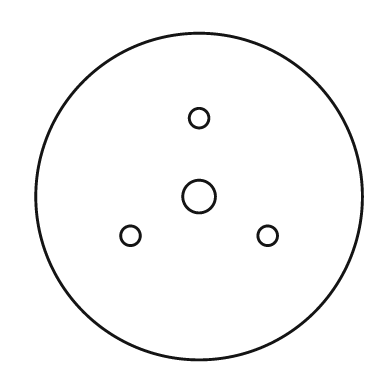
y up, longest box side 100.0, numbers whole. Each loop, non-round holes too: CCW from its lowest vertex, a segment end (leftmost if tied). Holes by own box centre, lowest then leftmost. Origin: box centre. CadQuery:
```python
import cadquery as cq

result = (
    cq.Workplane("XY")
    .moveTo(0.0, 0.0)
    .circle(50.0)
    .moveTo(-21.0, -12.0)
    .circle(3.0)
    .moveTo(21.0, -12.0)
    .circle(3.0)
    .moveTo(0.0, 0.0)
    .circle(5.0)
    .moveTo(0.0, 24.0)
    .circle(3.0)
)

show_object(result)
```